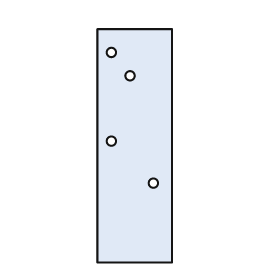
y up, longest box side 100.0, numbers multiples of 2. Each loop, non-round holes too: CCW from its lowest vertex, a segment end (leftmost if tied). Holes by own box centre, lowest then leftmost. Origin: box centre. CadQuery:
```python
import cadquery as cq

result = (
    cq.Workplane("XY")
    .moveTo(-16.0, -50.0)
    .lineTo(16.0, -50.0)
    .lineTo(16.0, 50.0)
    .lineTo(-16.0, 50.0)
    .close()
    .moveTo(8.0, -16.0)
    .circle(2.0)
    .moveTo(-10.0, 2.0)
    .circle(2.0)
    .moveTo(-2.0, 30.0)
    .circle(2.0)
    .moveTo(-10.0, 40.0)
    .circle(2.0)
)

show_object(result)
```